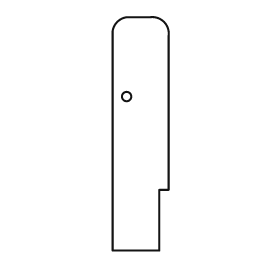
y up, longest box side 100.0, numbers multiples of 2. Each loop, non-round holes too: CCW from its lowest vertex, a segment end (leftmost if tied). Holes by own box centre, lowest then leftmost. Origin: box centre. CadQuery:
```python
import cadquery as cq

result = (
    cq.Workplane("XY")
    .moveTo(-12.0, -50.0)
    .lineTo(8.0, -50.0)
    .lineTo(8.0, -24.0)
    .lineTo(12.0, -24.0)
    .lineTo(12.0, 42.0)
    .threePointArc((10.0, 48.0), (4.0, 50.0))
    .lineTo(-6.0, 50.0)
    .threePointArc((-10.0, 48.0), (-12.0, 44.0))
    .close()
    .moveTo(-6.0, 16.0)
    .circle(2.0)
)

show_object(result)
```